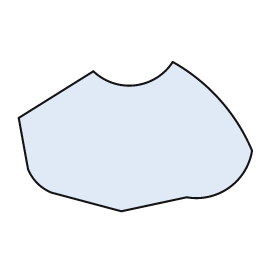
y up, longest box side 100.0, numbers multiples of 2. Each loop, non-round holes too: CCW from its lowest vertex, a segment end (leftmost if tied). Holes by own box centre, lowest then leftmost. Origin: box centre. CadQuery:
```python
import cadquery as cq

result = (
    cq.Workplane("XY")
    .moveTo(-6.0, -32.0)
    .lineTo(22.0, -26.0)
    .threePointArc((40.0, -22.0), (50.0, -6.0))
    .threePointArc((36.0, 16.0), (16.0, 32.0))
    .threePointArc((0.0, 22.0), (-18.0, 28.0))
    .lineTo(-50.0, 8.0)
    .lineTo(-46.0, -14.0)
    .threePointArc((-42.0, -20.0), (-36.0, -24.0))
    .close()
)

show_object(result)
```